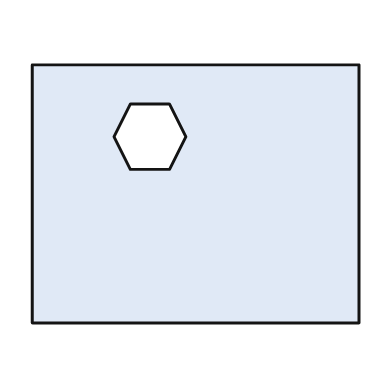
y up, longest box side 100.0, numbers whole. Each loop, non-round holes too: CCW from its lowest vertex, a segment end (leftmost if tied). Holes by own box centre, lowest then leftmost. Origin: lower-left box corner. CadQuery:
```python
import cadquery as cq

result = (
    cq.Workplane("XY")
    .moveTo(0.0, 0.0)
    .lineTo(100.0, 0.0)
    .lineTo(100.0, 79.0)
    .lineTo(0.0, 79.0)
    .close()
    .moveTo(30.0, 47.0)
    .lineTo(42.0, 47.0)
    .lineTo(47.0, 57.0)
    .lineTo(42.0, 67.0)
    .lineTo(30.0, 67.0)
    .lineTo(25.0, 57.0)
    .close()
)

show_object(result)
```